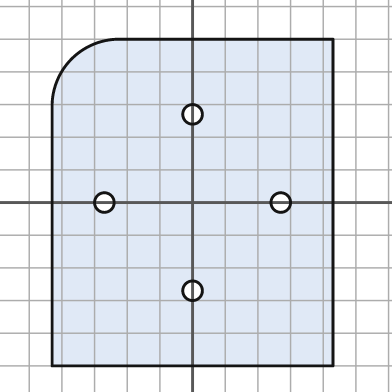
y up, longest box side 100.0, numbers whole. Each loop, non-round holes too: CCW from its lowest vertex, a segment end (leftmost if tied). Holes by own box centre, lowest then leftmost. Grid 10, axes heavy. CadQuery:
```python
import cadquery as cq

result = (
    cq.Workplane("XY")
    .moveTo(-43.0, -50.0)
    .lineTo(43.0, -50.0)
    .lineTo(43.0, 50.0)
    .lineTo(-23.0, 50.0)
    .threePointArc((-37.0, 44.0), (-43.0, 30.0))
    .close()
    .moveTo(0.0, -27.0)
    .circle(3.0)
    .moveTo(-27.0, 0.0)
    .circle(3.0)
    .moveTo(27.0, 0.0)
    .circle(3.0)
    .moveTo(0.0, 27.0)
    .circle(3.0)
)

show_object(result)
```